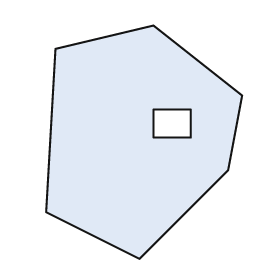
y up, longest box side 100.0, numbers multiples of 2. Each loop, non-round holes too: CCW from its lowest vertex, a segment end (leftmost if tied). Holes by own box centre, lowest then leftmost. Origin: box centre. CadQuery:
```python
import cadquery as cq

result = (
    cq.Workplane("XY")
    .moveTo(-2.0, -50.0)
    .lineTo(36.0, -12.0)
    .lineTo(42.0, 20.0)
    .lineTo(4.0, 50.0)
    .lineTo(-38.0, 40.0)
    .lineTo(-42.0, -30.0)
    .close()
    .moveTo(4.0, 2.0)
    .lineTo(20.0, 2.0)
    .lineTo(20.0, 14.0)
    .lineTo(4.0, 14.0)
    .close()
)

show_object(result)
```